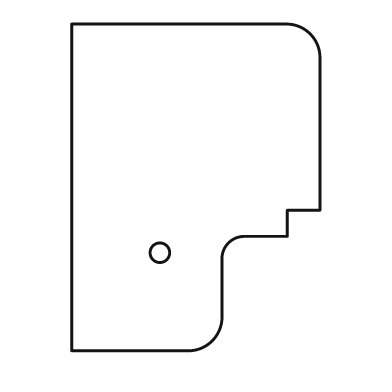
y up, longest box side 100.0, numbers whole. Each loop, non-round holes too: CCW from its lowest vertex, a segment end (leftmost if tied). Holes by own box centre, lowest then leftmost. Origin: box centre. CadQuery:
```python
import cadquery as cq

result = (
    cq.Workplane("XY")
    .moveTo(-38.0, -50.0)
    .lineTo(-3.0, -50.0)
    .threePointArc((5.0, -47.0), (8.0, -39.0))
    .lineTo(8.0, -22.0)
    .threePointArc((10.0, -17.0), (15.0, -15.0))
    .lineTo(28.0, -15.0)
    .lineTo(28.0, -7.0)
    .lineTo(38.0, -7.0)
    .lineTo(38.0, 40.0)
    .threePointArc((35.0, 47.0), (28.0, 50.0))
    .lineTo(-38.0, 50.0)
    .close()
    .moveTo(-11.0, -20.0)
    .circle(3.0)
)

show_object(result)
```